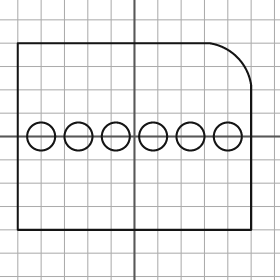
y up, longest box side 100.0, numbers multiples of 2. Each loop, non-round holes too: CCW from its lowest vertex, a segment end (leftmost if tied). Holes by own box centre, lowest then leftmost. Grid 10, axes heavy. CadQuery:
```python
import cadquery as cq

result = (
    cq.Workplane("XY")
    .moveTo(-50.0, -40.0)
    .lineTo(50.0, -40.0)
    .lineTo(50.0, 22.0)
    .threePointArc((44.0, 34.0), (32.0, 40.0))
    .lineTo(-50.0, 40.0)
    .close()
    .moveTo(-40.0, 0.0)
    .circle(6.0)
    .moveTo(-24.0, 0.0)
    .circle(6.0)
    .moveTo(-8.0, 0.0)
    .circle(6.0)
    .moveTo(8.0, 0.0)
    .circle(6.0)
    .moveTo(24.0, 0.0)
    .circle(6.0)
    .moveTo(40.0, 0.0)
    .circle(6.0)
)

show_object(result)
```